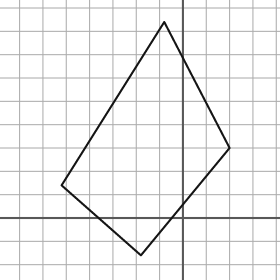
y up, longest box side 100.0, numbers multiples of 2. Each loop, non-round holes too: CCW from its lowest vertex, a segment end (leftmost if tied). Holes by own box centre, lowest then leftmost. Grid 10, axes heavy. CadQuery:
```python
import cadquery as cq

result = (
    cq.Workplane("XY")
    .moveTo(-18.0, -16.0)
    .lineTo(20.0, 30.0)
    .lineTo(-8.0, 84.0)
    .lineTo(-52.0, 14.0)
    .close()
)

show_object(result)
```